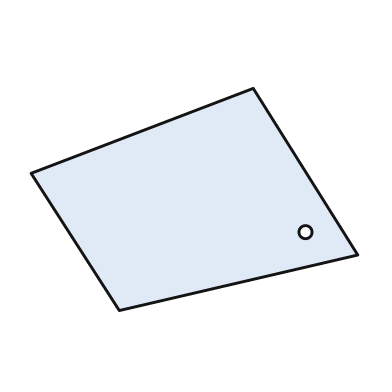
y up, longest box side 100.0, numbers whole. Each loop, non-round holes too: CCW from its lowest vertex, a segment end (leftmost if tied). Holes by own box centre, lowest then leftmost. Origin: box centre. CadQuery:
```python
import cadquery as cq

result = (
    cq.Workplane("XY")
    .moveTo(-23.0, -34.0)
    .lineTo(50.0, -17.0)
    .lineTo(18.0, 34.0)
    .lineTo(-50.0, 8.0)
    .close()
    .moveTo(34.0, -10.0)
    .circle(2.0)
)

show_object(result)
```